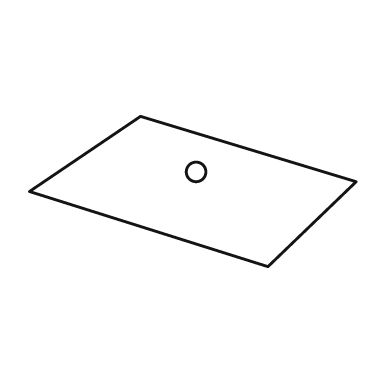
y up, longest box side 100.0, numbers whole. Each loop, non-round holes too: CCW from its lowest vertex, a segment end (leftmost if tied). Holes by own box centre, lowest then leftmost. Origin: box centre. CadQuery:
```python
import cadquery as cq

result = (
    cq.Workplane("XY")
    .moveTo(23.0, -23.0)
    .lineTo(50.0, 3.0)
    .lineTo(-16.0, 23.0)
    .lineTo(-50.0, 0.0)
    .close()
    .moveTo(1.0, 6.0)
    .circle(3.0)
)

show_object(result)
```